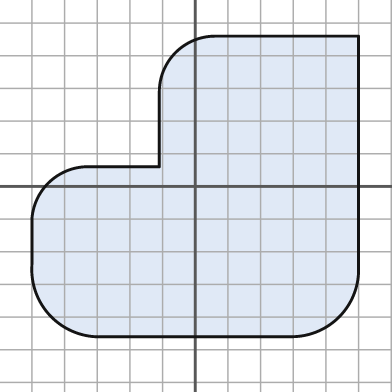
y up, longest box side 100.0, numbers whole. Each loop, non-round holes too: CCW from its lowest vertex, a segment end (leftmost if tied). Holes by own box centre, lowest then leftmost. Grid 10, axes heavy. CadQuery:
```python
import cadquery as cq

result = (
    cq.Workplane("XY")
    .moveTo(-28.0, -46.0)
    .lineTo(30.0, -46.0)
    .threePointArc((44.0, -40.0), (50.0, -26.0))
    .lineTo(50.0, 46.0)
    .lineTo(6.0, 46.0)
    .threePointArc((-6.0, 41.0), (-11.0, 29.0))
    .lineTo(-11.0, 6.0)
    .lineTo(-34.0, 6.0)
    .threePointArc((-45.0, 1.0), (-50.0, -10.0))
    .lineTo(-50.0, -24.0)
    .threePointArc((-44.0, -40.0), (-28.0, -46.0))
    .close()
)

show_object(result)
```